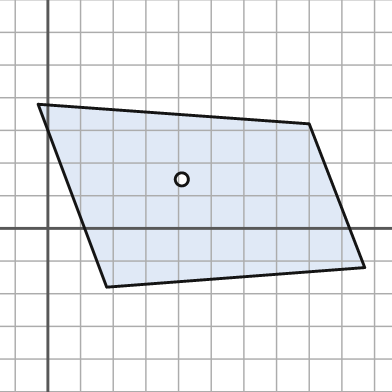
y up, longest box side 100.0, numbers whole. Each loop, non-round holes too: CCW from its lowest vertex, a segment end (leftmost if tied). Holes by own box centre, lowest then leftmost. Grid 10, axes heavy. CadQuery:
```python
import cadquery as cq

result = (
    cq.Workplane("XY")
    .moveTo(18.0, -18.0)
    .lineTo(97.0, -12.0)
    .lineTo(80.0, 32.0)
    .lineTo(-3.0, 38.0)
    .close()
    .moveTo(41.0, 15.0)
    .circle(2.0)
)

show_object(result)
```